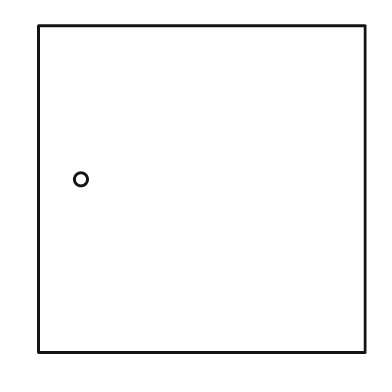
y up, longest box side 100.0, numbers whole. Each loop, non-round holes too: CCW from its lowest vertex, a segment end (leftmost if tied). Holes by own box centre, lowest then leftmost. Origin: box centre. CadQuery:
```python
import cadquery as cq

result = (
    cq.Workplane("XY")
    .moveTo(-50.0, -50.0)
    .lineTo(50.0, -50.0)
    .lineTo(50.0, 50.0)
    .lineTo(-50.0, 50.0)
    .close()
    .moveTo(-37.0, 3.0)
    .circle(2.0)
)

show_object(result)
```